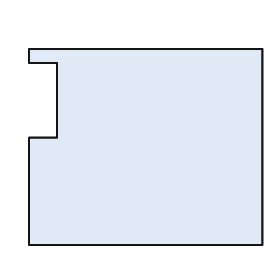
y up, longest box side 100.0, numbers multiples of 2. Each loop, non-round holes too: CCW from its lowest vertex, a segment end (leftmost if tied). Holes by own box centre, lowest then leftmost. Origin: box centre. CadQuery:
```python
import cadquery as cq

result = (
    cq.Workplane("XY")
    .moveTo(-50.0, -42.0)
    .lineTo(50.0, -42.0)
    .lineTo(50.0, 42.0)
    .lineTo(-50.0, 42.0)
    .lineTo(-50.0, 36.0)
    .lineTo(-38.0, 36.0)
    .lineTo(-38.0, 4.0)
    .lineTo(-50.0, 4.0)
    .close()
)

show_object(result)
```